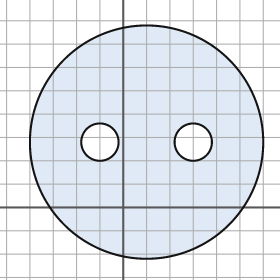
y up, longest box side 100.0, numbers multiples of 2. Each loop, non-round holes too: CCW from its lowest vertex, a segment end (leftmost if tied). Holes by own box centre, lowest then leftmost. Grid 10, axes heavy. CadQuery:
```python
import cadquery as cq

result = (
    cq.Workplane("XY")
    .moveTo(10.0, 28.0)
    .circle(50.0)
    .moveTo(-10.0, 28.0)
    .circle(8.0)
    .moveTo(30.0, 28.0)
    .circle(8.0)
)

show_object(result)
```